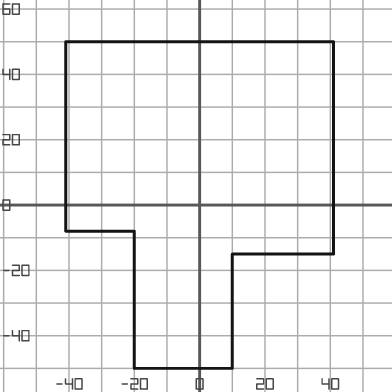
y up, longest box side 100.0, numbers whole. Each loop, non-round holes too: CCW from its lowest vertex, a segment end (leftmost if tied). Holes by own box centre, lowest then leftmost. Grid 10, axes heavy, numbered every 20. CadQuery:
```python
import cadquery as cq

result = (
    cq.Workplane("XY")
    .moveTo(-20.0, -50.0)
    .lineTo(10.0, -50.0)
    .lineTo(10.0, -15.0)
    .lineTo(41.0, -15.0)
    .lineTo(41.0, 50.0)
    .lineTo(-41.0, 50.0)
    .lineTo(-41.0, -8.0)
    .lineTo(-20.0, -8.0)
    .close()
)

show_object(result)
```